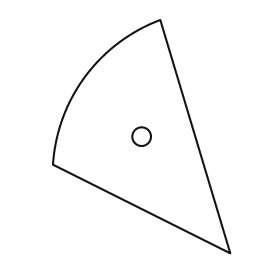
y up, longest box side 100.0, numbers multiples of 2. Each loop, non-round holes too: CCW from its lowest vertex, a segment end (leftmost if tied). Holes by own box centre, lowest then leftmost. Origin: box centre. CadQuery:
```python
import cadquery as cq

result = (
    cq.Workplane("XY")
    .moveTo(38.0, -50.0)
    .lineTo(8.0, 50.0)
    .threePointArc((-24.0, 26.0), (-38.0, -12.0))
    .close()
    .moveTo(0.0, 0.0)
    .circle(4.0)
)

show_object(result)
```